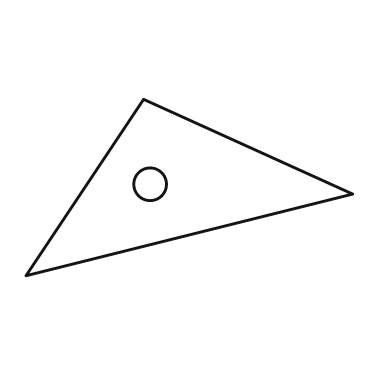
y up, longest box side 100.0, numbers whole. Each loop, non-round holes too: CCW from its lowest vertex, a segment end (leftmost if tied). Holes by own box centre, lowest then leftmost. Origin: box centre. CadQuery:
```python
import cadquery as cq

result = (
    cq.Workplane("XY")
    .moveTo(-50.0, -27.0)
    .lineTo(50.0, -2.0)
    .lineTo(-14.0, 27.0)
    .close()
    .moveTo(-12.0, 1.0)
    .circle(5.0)
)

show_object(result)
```